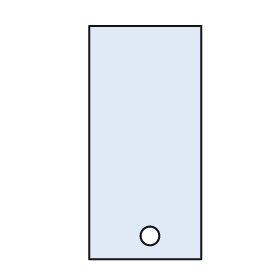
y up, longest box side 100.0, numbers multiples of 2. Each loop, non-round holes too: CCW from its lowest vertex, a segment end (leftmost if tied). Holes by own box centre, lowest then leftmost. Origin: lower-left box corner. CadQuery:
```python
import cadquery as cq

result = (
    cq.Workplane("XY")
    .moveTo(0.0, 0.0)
    .lineTo(48.0, 0.0)
    .lineTo(48.0, 100.0)
    .lineTo(0.0, 100.0)
    .close()
    .moveTo(26.0, 10.0)
    .circle(4.0)
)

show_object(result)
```